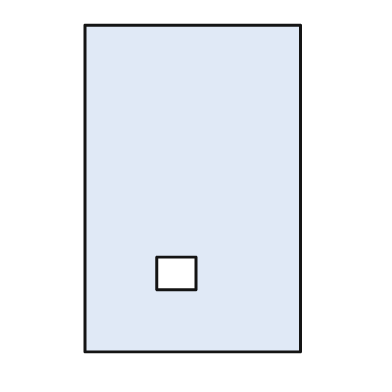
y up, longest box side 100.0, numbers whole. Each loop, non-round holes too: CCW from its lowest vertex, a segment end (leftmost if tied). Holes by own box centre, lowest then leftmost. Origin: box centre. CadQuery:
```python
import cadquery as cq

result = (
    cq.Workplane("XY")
    .moveTo(-33.0, -50.0)
    .lineTo(33.0, -50.0)
    .lineTo(33.0, 50.0)
    .lineTo(-33.0, 50.0)
    .close()
    .moveTo(-11.0, -31.0)
    .lineTo(1.0, -31.0)
    .lineTo(1.0, -21.0)
    .lineTo(-11.0, -21.0)
    .close()
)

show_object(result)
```